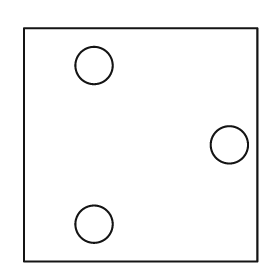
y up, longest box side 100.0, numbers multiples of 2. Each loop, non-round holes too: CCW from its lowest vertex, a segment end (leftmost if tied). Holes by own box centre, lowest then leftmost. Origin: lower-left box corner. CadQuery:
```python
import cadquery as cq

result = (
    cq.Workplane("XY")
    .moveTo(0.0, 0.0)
    .lineTo(100.0, 0.0)
    .lineTo(100.0, 100.0)
    .lineTo(0.0, 100.0)
    .close()
    .moveTo(30.0, 16.0)
    .circle(8.0)
    .moveTo(88.0, 50.0)
    .circle(8.0)
    .moveTo(30.0, 84.0)
    .circle(8.0)
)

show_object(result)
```